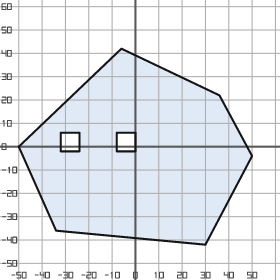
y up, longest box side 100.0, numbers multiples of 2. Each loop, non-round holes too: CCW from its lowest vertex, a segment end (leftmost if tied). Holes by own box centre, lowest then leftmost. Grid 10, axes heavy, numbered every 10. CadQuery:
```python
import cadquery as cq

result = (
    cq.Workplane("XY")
    .moveTo(30.0, -42.0)
    .lineTo(50.0, -4.0)
    .lineTo(36.0, 22.0)
    .lineTo(-6.0, 42.0)
    .lineTo(-50.0, 0.0)
    .lineTo(-34.0, -36.0)
    .close()
    .moveTo(-32.0, -2.0)
    .lineTo(-24.0, -2.0)
    .lineTo(-24.0, 6.0)
    .lineTo(-32.0, 6.0)
    .close()
    .moveTo(-8.0, -2.0)
    .lineTo(0.0, -2.0)
    .lineTo(0.0, 6.0)
    .lineTo(-8.0, 6.0)
    .close()
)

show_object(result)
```